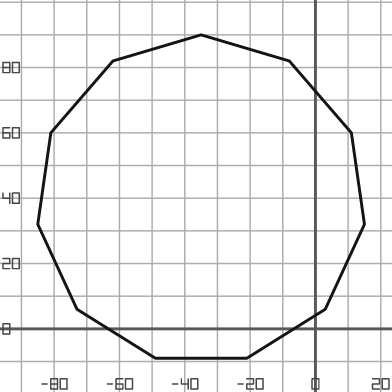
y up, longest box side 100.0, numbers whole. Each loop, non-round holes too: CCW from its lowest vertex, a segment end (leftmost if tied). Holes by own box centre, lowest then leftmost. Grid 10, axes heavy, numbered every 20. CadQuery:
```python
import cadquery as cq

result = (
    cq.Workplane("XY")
    .moveTo(-49.0, -9.0)
    .lineTo(-21.0, -9.0)
    .lineTo(3.0, 6.0)
    .lineTo(15.0, 32.0)
    .lineTo(11.0, 60.0)
    .lineTo(-8.0, 82.0)
    .lineTo(-35.0, 90.0)
    .lineTo(-62.0, 82.0)
    .lineTo(-81.0, 60.0)
    .lineTo(-85.0, 32.0)
    .lineTo(-73.0, 6.0)
    .close()
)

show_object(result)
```